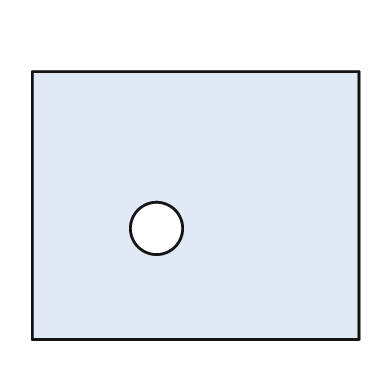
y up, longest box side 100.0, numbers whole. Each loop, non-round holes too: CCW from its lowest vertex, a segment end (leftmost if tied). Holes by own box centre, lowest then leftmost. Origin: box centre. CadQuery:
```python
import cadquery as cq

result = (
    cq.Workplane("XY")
    .moveTo(-50.0, -41.0)
    .lineTo(50.0, -41.0)
    .lineTo(50.0, 41.0)
    .lineTo(-50.0, 41.0)
    .close()
    .moveTo(-12.0, -7.0)
    .circle(8.0)
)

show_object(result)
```